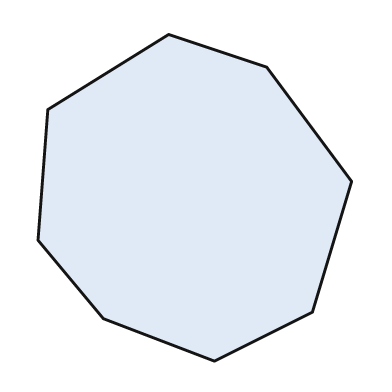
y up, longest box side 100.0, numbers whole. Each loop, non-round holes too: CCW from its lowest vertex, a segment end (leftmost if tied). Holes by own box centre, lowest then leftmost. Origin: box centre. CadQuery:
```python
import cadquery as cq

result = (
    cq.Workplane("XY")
    .moveTo(6.0, -50.0)
    .lineTo(36.0, -35.0)
    .lineTo(48.0, 5.0)
    .lineTo(22.0, 40.0)
    .lineTo(-8.0, 50.0)
    .lineTo(-45.0, 27.0)
    .lineTo(-48.0, -13.0)
    .lineTo(-28.0, -37.0)
    .close()
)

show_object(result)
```